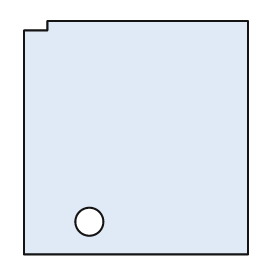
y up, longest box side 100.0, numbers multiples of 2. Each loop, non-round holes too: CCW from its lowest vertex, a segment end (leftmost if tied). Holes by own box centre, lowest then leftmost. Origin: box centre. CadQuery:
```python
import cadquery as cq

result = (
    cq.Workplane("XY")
    .moveTo(-48.0, -50.0)
    .lineTo(48.0, -50.0)
    .lineTo(48.0, 50.0)
    .lineTo(-38.0, 50.0)
    .lineTo(-38.0, 46.0)
    .lineTo(-48.0, 46.0)
    .close()
    .moveTo(-20.0, -36.0)
    .circle(6.0)
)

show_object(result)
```